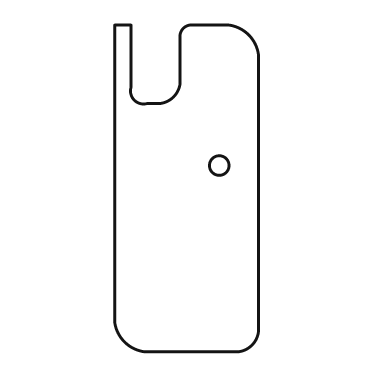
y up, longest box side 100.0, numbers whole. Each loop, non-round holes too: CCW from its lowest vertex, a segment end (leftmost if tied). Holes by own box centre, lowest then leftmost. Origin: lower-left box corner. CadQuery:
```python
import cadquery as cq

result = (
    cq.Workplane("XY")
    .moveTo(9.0, 0.0)
    .lineTo(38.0, 0.0)
    .threePointArc((42.0, 2.0), (44.0, 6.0))
    .lineTo(44.0, 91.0)
    .threePointArc((41.0, 97.0), (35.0, 100.0))
    .lineTo(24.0, 100.0)
    .threePointArc((21.0, 99.0), (20.0, 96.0))
    .lineTo(20.0, 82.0)
    .threePointArc((18.0, 78.0), (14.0, 76.0))
    .lineTo(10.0, 76.0)
    .threePointArc((6.0, 77.0), (5.0, 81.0))
    .lineTo(5.0, 100.0)
    .lineTo(0.0, 100.0)
    .lineTo(0.0, 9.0)
    .threePointArc((3.0, 3.0), (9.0, 0.0))
    .close()
    .moveTo(32.0, 57.0)
    .circle(3.0)
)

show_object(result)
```